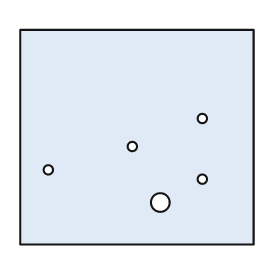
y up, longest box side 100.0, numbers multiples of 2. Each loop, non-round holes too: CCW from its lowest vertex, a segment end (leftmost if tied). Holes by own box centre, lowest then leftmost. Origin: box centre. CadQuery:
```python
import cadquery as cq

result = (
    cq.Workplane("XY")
    .moveTo(-50.0, -46.0)
    .lineTo(50.0, -46.0)
    .lineTo(50.0, 46.0)
    .lineTo(-50.0, 46.0)
    .close()
    .moveTo(10.0, -28.0)
    .circle(4.0)
    .moveTo(28.0, -18.0)
    .circle(2.0)
    .moveTo(-38.0, -14.0)
    .circle(2.0)
    .moveTo(-2.0, -4.0)
    .circle(2.0)
    .moveTo(28.0, 8.0)
    .circle(2.0)
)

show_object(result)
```